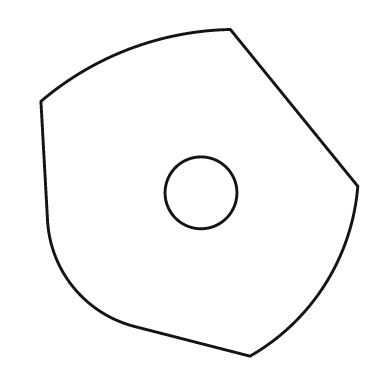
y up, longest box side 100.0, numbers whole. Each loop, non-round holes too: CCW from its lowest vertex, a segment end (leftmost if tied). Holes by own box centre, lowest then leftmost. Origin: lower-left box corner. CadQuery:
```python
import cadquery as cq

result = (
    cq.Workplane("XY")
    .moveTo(64.0, 0.0)
    .threePointArc((87.0, 22.0), (97.0, 52.0))
    .lineTo(58.0, 100.0)
    .threePointArc((27.0, 94.0), (0.0, 78.0))
    .lineTo(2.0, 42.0)
    .threePointArc((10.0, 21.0), (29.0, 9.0))
    .close()
    .moveTo(49.0, 50.0)
    .circle(11.0)
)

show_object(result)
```